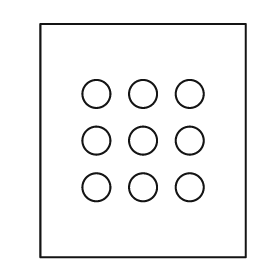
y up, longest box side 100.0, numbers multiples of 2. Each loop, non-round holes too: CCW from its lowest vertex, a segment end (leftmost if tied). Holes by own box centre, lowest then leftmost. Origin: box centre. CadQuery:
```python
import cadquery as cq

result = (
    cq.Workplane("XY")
    .moveTo(-44.0, -50.0)
    .lineTo(44.0, -50.0)
    .lineTo(44.0, 50.0)
    .lineTo(-44.0, 50.0)
    .close()
    .moveTo(-20.0, -20.0)
    .circle(6.0)
    .moveTo(0.0, -20.0)
    .circle(6.0)
    .moveTo(20.0, -20.0)
    .circle(6.0)
    .moveTo(-20.0, 0.0)
    .circle(6.0)
    .moveTo(0.0, 0.0)
    .circle(6.0)
    .moveTo(20.0, 0.0)
    .circle(6.0)
    .moveTo(-20.0, 20.0)
    .circle(6.0)
    .moveTo(0.0, 20.0)
    .circle(6.0)
    .moveTo(20.0, 20.0)
    .circle(6.0)
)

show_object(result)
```